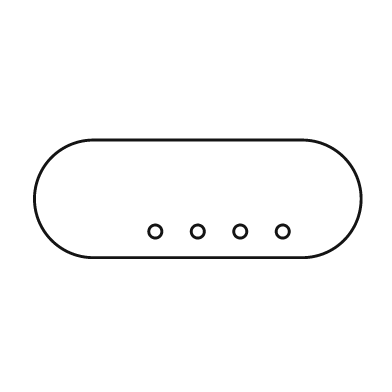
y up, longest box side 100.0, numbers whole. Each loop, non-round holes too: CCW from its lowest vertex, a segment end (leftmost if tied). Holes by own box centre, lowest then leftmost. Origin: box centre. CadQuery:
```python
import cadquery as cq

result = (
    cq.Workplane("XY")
    .moveTo(-32.0, -18.0)
    .lineTo(32.0, -18.0)
    .threePointArc((50.0, 0.0), (32.0, 18.0))
    .lineTo(-32.0, 18.0)
    .threePointArc((-50.0, 0.0), (-32.0, -18.0))
    .close()
    .moveTo(-13.0, -10.0)
    .circle(2.0)
    .moveTo(0.0, -10.0)
    .circle(2.0)
    .moveTo(13.0, -10.0)
    .circle(2.0)
    .moveTo(26.0, -10.0)
    .circle(2.0)
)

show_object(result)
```